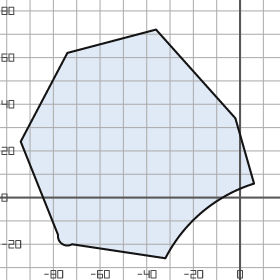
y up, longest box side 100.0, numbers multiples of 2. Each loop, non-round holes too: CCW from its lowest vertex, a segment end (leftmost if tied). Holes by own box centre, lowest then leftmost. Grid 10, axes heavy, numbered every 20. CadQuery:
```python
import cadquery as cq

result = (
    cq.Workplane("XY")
    .moveTo(-32.0, -26.0)
    .threePointArc((-16.0, -6.0), (6.0, 6.0))
    .lineTo(-2.0, 34.0)
    .lineTo(-36.0, 72.0)
    .lineTo(-74.0, 62.0)
    .lineTo(-94.0, 24.0)
    .lineTo(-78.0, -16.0)
    .threePointArc((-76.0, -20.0), (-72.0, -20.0))
    .close()
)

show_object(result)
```